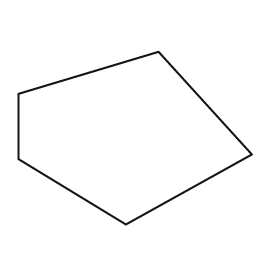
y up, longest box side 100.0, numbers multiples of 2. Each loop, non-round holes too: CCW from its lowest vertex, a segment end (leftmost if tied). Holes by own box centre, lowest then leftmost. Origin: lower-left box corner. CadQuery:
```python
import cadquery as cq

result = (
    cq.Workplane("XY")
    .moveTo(46.0, 0.0)
    .lineTo(100.0, 30.0)
    .lineTo(60.0, 74.0)
    .lineTo(0.0, 56.0)
    .lineTo(0.0, 28.0)
    .close()
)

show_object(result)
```